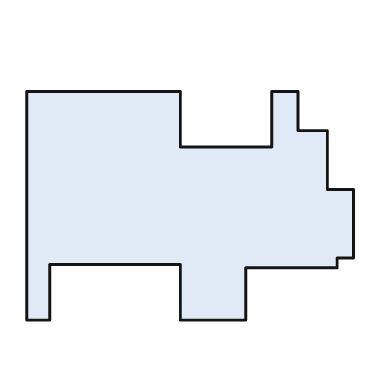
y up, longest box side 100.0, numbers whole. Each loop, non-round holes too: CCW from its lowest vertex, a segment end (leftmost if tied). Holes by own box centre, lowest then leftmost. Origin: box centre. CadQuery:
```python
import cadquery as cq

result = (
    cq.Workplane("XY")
    .moveTo(-50.0, -35.0)
    .lineTo(-43.0, -35.0)
    .lineTo(-43.0, -18.0)
    .lineTo(-3.0, -18.0)
    .lineTo(-3.0, -35.0)
    .lineTo(17.0, -35.0)
    .lineTo(17.0, -19.0)
    .lineTo(45.0, -19.0)
    .lineTo(45.0, -16.0)
    .lineTo(50.0, -16.0)
    .lineTo(50.0, 5.0)
    .lineTo(42.0, 5.0)
    .lineTo(42.0, 23.0)
    .lineTo(33.0, 23.0)
    .lineTo(33.0, 35.0)
    .lineTo(25.0, 35.0)
    .lineTo(25.0, 18.0)
    .lineTo(-3.0, 18.0)
    .lineTo(-3.0, 35.0)
    .lineTo(-50.0, 35.0)
    .close()
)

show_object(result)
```